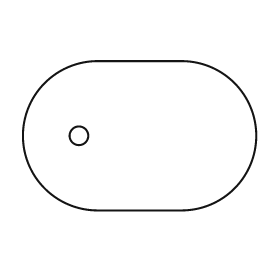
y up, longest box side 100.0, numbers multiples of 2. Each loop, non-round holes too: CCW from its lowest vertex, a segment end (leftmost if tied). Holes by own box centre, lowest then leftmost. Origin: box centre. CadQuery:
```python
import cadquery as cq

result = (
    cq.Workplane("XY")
    .moveTo(-18.0, -32.0)
    .lineTo(18.0, -32.0)
    .threePointArc((50.0, 0.0), (18.0, 32.0))
    .lineTo(-18.0, 32.0)
    .threePointArc((-50.0, 0.0), (-18.0, -32.0))
    .close()
    .moveTo(-26.0, 0.0)
    .circle(4.0)
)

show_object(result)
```